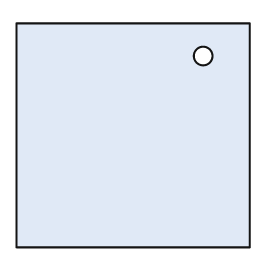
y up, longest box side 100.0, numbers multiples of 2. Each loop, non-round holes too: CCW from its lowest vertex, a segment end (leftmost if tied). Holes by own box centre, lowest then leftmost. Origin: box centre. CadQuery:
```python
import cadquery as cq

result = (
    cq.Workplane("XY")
    .moveTo(-50.0, -48.0)
    .lineTo(50.0, -48.0)
    .lineTo(50.0, 48.0)
    .lineTo(-50.0, 48.0)
    .close()
    .moveTo(30.0, 34.0)
    .circle(4.0)
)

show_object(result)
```